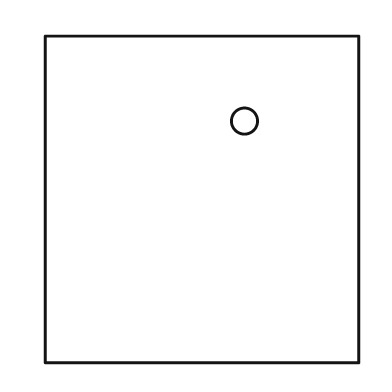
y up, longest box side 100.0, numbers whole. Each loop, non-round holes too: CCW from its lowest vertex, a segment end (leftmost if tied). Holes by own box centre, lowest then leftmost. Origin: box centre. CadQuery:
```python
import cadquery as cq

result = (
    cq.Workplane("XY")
    .moveTo(-48.0, -50.0)
    .lineTo(48.0, -50.0)
    .lineTo(48.0, 50.0)
    .lineTo(-48.0, 50.0)
    .close()
    .moveTo(13.0, 24.0)
    .circle(4.0)
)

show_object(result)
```